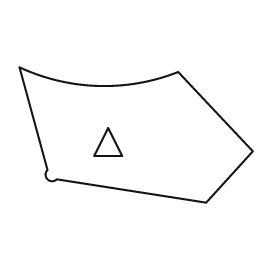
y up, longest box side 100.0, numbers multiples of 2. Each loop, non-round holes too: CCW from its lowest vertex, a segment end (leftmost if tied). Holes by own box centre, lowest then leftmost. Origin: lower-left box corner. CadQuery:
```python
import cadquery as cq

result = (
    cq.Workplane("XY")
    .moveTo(80.0, 0.0)
    .lineTo(100.0, 22.0)
    .lineTo(68.0, 56.0)
    .threePointArc((34.0, 50.0), (0.0, 58.0))
    .lineTo(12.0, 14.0)
    .threePointArc((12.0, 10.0), (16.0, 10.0))
    .close()
    .moveTo(32.0, 20.0)
    .lineTo(44.0, 20.0)
    .lineTo(38.0, 32.0)
    .close()
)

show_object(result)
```